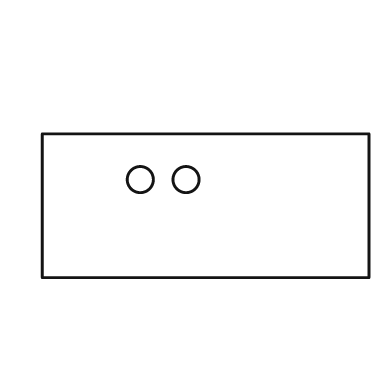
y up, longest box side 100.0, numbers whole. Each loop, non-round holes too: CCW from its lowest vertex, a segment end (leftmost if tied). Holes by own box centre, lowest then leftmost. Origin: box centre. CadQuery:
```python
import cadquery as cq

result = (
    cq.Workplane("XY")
    .moveTo(-50.0, -22.0)
    .lineTo(50.0, -22.0)
    .lineTo(50.0, 22.0)
    .lineTo(-50.0, 22.0)
    .close()
    .moveTo(-20.0, 8.0)
    .circle(4.0)
    .moveTo(-6.0, 8.0)
    .circle(4.0)
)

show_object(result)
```